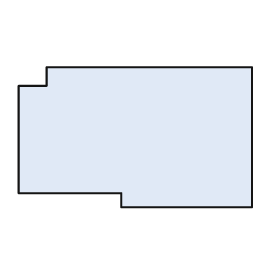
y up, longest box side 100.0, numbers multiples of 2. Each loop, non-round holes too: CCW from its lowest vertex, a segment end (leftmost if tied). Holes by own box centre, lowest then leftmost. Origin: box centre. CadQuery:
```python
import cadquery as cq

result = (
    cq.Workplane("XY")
    .moveTo(-6.0, -30.0)
    .lineTo(50.0, -30.0)
    .lineTo(50.0, 30.0)
    .lineTo(-38.0, 30.0)
    .lineTo(-38.0, 22.0)
    .lineTo(-50.0, 22.0)
    .lineTo(-50.0, -24.0)
    .lineTo(-6.0, -24.0)
    .close()
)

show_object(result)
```